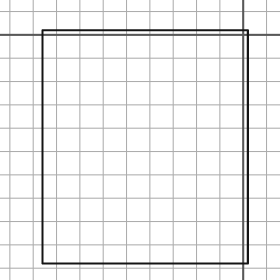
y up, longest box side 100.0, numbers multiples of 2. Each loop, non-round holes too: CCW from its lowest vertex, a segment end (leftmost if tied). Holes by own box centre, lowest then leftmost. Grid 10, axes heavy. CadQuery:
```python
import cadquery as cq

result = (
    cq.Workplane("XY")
    .moveTo(-86.0, -98.0)
    .lineTo(2.0, -98.0)
    .lineTo(2.0, 2.0)
    .lineTo(-86.0, 2.0)
    .close()
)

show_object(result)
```